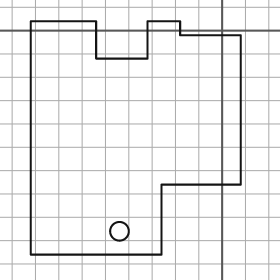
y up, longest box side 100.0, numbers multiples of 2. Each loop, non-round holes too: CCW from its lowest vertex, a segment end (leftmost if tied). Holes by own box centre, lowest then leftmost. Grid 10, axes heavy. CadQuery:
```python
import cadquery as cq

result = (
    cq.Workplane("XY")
    .moveTo(-82.0, -96.0)
    .lineTo(-26.0, -96.0)
    .lineTo(-26.0, -66.0)
    .lineTo(8.0, -66.0)
    .lineTo(8.0, -2.0)
    .lineTo(-18.0, -2.0)
    .lineTo(-18.0, 4.0)
    .lineTo(-32.0, 4.0)
    .lineTo(-32.0, -12.0)
    .lineTo(-54.0, -12.0)
    .lineTo(-54.0, 4.0)
    .lineTo(-82.0, 4.0)
    .close()
    .moveTo(-44.0, -86.0)
    .circle(4.0)
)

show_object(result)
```